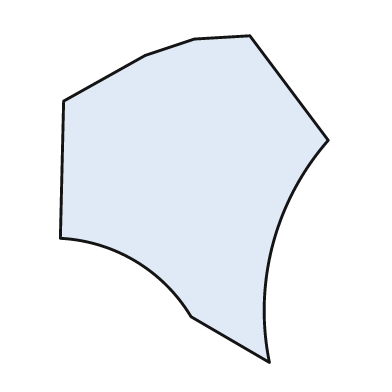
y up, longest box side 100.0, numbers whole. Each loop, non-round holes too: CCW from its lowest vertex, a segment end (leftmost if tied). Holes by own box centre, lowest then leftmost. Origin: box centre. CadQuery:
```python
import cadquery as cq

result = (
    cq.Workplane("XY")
    .moveTo(23.0, -50.0)
    .threePointArc((24.0, -14.0), (41.0, 18.0))
    .lineTo(17.0, 50.0)
    .lineTo(0.0, 49.0)
    .lineTo(-15.0, 44.0)
    .lineTo(-40.0, 30.0)
    .lineTo(-41.0, -12.0)
    .threePointArc((-18.0, -19.0), (-1.0, -36.0))
    .close()
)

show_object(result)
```